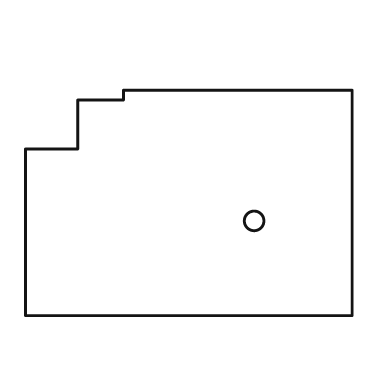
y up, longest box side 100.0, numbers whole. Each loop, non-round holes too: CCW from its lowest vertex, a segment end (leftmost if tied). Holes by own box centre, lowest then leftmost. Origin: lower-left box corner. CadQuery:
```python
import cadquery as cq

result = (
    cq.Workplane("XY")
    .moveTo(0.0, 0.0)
    .lineTo(100.0, 0.0)
    .lineTo(100.0, 69.0)
    .lineTo(30.0, 69.0)
    .lineTo(30.0, 66.0)
    .lineTo(16.0, 66.0)
    .lineTo(16.0, 51.0)
    .lineTo(0.0, 51.0)
    .close()
    .moveTo(70.0, 29.0)
    .circle(3.0)
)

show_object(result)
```